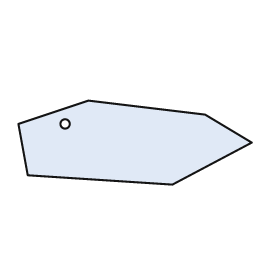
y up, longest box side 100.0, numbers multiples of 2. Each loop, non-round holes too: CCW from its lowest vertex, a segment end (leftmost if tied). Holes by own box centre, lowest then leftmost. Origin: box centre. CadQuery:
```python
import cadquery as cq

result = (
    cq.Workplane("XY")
    .moveTo(16.0, -18.0)
    .lineTo(50.0, 0.0)
    .lineTo(30.0, 12.0)
    .lineTo(-20.0, 18.0)
    .lineTo(-50.0, 8.0)
    .lineTo(-46.0, -14.0)
    .close()
    .moveTo(-30.0, 8.0)
    .circle(2.0)
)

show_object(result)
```